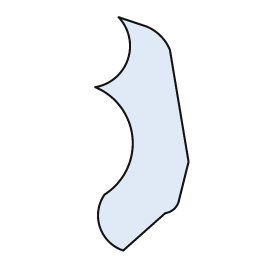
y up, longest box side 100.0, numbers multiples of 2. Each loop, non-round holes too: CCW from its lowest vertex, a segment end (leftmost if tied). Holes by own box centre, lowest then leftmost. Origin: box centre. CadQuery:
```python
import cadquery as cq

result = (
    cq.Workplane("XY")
    .moveTo(-8.0, -50.0)
    .lineTo(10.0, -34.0)
    .threePointArc((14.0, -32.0), (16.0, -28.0))
    .lineTo(20.0, -12.0)
    .lineTo(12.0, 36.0)
    .threePointArc((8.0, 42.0), (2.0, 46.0))
    .lineTo(-10.0, 50.0)
    .threePointArc((-6.0, 32.0), (-20.0, 20.0))
    .threePointArc((-4.0, -2.0), (-16.0, -26.0))
    .threePointArc((-18.0, -40.0), (-8.0, -50.0))
    .close()
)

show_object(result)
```